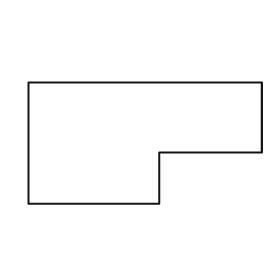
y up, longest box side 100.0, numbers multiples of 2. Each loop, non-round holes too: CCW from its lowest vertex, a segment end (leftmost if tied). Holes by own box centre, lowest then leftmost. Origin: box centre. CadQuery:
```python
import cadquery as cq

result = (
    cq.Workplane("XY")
    .moveTo(-50.0, -26.0)
    .lineTo(6.0, -26.0)
    .lineTo(6.0, -4.0)
    .lineTo(50.0, -4.0)
    .lineTo(50.0, 26.0)
    .lineTo(-50.0, 26.0)
    .close()
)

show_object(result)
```